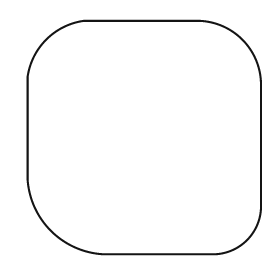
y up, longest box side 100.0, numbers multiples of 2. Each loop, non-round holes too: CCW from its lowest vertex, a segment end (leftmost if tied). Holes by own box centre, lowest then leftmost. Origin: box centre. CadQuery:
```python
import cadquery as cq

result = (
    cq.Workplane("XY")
    .moveTo(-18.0, -50.0)
    .lineTo(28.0, -50.0)
    .threePointArc((44.0, -44.0), (50.0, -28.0))
    .lineTo(50.0, 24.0)
    .threePointArc((42.0, 42.0), (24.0, 50.0))
    .lineTo(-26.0, 50.0)
    .threePointArc((-42.0, 42.0), (-50.0, 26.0))
    .lineTo(-50.0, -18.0)
    .threePointArc((-40.0, -40.0), (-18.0, -50.0))
    .close()
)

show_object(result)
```